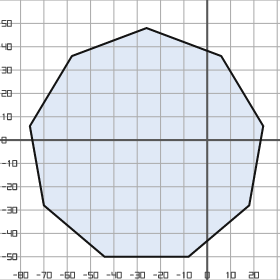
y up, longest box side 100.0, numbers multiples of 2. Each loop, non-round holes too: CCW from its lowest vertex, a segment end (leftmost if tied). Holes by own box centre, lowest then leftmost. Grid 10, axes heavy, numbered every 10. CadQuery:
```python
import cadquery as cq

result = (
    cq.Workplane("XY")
    .moveTo(-44.0, -50.0)
    .lineTo(-8.0, -50.0)
    .lineTo(18.0, -28.0)
    .lineTo(24.0, 6.0)
    .lineTo(6.0, 36.0)
    .lineTo(-26.0, 48.0)
    .lineTo(-58.0, 36.0)
    .lineTo(-76.0, 6.0)
    .lineTo(-70.0, -28.0)
    .close()
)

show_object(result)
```